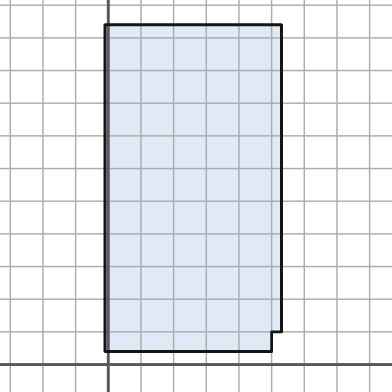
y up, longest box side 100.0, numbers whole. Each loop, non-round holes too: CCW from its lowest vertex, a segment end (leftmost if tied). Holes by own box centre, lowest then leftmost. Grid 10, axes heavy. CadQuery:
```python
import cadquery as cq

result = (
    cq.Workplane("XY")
    .moveTo(-1.0, 4.0)
    .lineTo(50.0, 4.0)
    .lineTo(50.0, 10.0)
    .lineTo(53.0, 10.0)
    .lineTo(53.0, 104.0)
    .lineTo(-1.0, 104.0)
    .close()
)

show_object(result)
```